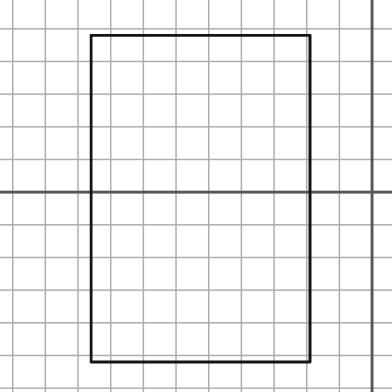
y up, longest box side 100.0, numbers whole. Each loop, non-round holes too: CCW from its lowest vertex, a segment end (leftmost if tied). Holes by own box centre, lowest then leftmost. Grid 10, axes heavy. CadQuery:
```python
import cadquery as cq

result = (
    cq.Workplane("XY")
    .moveTo(-86.0, -52.0)
    .lineTo(-19.0, -52.0)
    .lineTo(-19.0, 48.0)
    .lineTo(-86.0, 48.0)
    .close()
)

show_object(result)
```